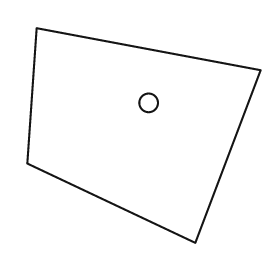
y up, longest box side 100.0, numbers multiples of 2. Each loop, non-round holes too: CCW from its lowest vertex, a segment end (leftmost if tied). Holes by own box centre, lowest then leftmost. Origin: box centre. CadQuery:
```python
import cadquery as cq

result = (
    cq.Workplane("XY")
    .moveTo(22.0, -46.0)
    .lineTo(50.0, 28.0)
    .lineTo(-46.0, 46.0)
    .lineTo(-50.0, -12.0)
    .close()
    .moveTo(2.0, 14.0)
    .circle(4.0)
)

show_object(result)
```